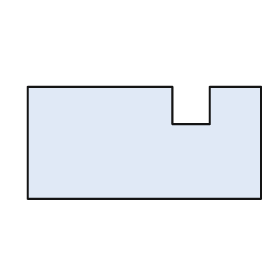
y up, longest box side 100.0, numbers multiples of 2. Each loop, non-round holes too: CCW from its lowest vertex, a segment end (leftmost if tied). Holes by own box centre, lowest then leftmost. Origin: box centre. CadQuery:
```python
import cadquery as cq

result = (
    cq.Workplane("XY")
    .moveTo(-50.0, -24.0)
    .lineTo(50.0, -24.0)
    .lineTo(50.0, 24.0)
    .lineTo(28.0, 24.0)
    .lineTo(28.0, 8.0)
    .lineTo(12.0, 8.0)
    .lineTo(12.0, 24.0)
    .lineTo(-50.0, 24.0)
    .close()
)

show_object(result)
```